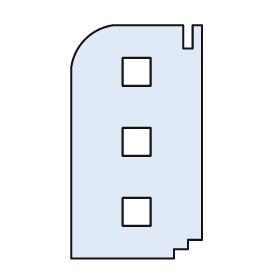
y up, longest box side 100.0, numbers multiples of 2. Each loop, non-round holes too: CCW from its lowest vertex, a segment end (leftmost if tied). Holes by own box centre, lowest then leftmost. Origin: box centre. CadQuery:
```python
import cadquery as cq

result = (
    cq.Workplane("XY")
    .moveTo(-28.0, -50.0)
    .lineTo(16.0, -50.0)
    .lineTo(16.0, -46.0)
    .lineTo(22.0, -46.0)
    .lineTo(22.0, -42.0)
    .lineTo(28.0, -42.0)
    .lineTo(28.0, 50.0)
    .lineTo(24.0, 50.0)
    .lineTo(24.0, 40.0)
    .lineTo(20.0, 40.0)
    .lineTo(20.0, 50.0)
    .lineTo(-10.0, 50.0)
    .threePointArc((-22.0, 44.0), (-28.0, 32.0))
    .close()
    .moveTo(-6.0, -36.0)
    .lineTo(6.0, -36.0)
    .lineTo(6.0, -24.0)
    .lineTo(-6.0, -24.0)
    .close()
    .moveTo(-6.0, -6.0)
    .lineTo(6.0, -6.0)
    .lineTo(6.0, 6.0)
    .lineTo(-6.0, 6.0)
    .close()
    .moveTo(-6.0, 24.0)
    .lineTo(6.0, 24.0)
    .lineTo(6.0, 36.0)
    .lineTo(-6.0, 36.0)
    .close()
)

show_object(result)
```